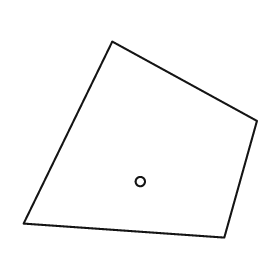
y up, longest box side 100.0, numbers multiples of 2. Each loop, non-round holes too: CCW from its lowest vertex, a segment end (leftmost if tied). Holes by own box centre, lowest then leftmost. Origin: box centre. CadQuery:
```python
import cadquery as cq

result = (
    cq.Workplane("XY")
    .moveTo(36.0, -42.0)
    .lineTo(50.0, 8.0)
    .lineTo(-12.0, 42.0)
    .lineTo(-50.0, -36.0)
    .close()
    .moveTo(0.0, -18.0)
    .circle(2.0)
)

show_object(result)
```